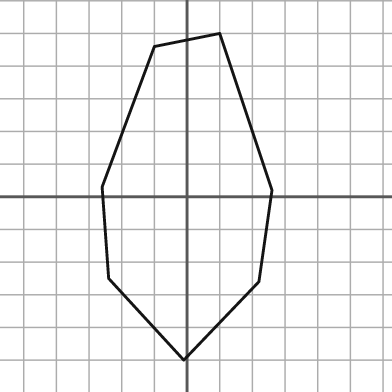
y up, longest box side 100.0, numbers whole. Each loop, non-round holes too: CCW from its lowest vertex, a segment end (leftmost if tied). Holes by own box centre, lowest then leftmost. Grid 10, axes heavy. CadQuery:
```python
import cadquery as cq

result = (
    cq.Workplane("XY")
    .moveTo(-1.0, -50.0)
    .lineTo(22.0, -26.0)
    .lineTo(26.0, 2.0)
    .lineTo(10.0, 50.0)
    .lineTo(-10.0, 46.0)
    .lineTo(-26.0, 3.0)
    .lineTo(-24.0, -25.0)
    .close()
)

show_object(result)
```